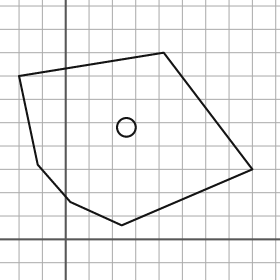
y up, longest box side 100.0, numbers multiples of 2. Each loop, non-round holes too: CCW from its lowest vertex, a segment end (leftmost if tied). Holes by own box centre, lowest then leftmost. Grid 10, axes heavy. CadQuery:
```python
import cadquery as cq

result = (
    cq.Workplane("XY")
    .moveTo(24.0, 6.0)
    .lineTo(80.0, 30.0)
    .lineTo(42.0, 80.0)
    .lineTo(-20.0, 70.0)
    .lineTo(-12.0, 32.0)
    .lineTo(2.0, 16.0)
    .close()
    .moveTo(26.0, 48.0)
    .circle(4.0)
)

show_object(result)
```